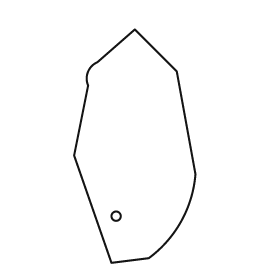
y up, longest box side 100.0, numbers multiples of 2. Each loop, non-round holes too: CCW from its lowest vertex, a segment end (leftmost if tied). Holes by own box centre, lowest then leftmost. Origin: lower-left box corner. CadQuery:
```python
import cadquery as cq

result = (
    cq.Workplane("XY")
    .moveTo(16.0, 0.0)
    .lineTo(32.0, 2.0)
    .threePointArc((46.0, 18.0), (52.0, 38.0))
    .lineTo(44.0, 82.0)
    .lineTo(26.0, 100.0)
    .lineTo(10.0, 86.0)
    .threePointArc((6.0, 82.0), (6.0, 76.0))
    .lineTo(0.0, 46.0)
    .close()
    .moveTo(18.0, 20.0)
    .circle(2.0)
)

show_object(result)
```